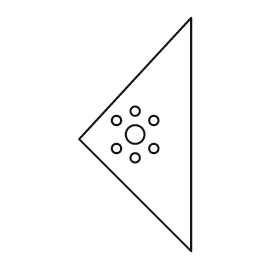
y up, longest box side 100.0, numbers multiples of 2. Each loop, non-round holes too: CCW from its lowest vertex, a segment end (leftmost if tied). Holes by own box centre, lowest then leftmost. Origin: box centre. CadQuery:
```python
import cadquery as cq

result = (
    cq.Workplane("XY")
    .moveTo(24.0, -50.0)
    .lineTo(24.0, 50.0)
    .lineTo(-24.0, -2.0)
    .close()
    .moveTo(0.0, -10.0)
    .circle(2.0)
    .moveTo(-8.0, -6.0)
    .circle(2.0)
    .moveTo(8.0, -6.0)
    .circle(2.0)
    .moveTo(0.0, 0.0)
    .circle(4.0)
    .moveTo(-8.0, 6.0)
    .circle(2.0)
    .moveTo(8.0, 6.0)
    .circle(2.0)
    .moveTo(0.0, 10.0)
    .circle(2.0)
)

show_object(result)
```